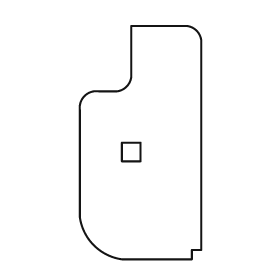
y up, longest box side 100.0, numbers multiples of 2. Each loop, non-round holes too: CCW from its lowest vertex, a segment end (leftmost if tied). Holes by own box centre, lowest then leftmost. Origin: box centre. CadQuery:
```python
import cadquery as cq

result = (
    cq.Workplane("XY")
    .moveTo(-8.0, -50.0)
    .lineTo(22.0, -50.0)
    .lineTo(22.0, -46.0)
    .lineTo(26.0, -46.0)
    .lineTo(26.0, 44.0)
    .threePointArc((24.0, 48.0), (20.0, 50.0))
    .lineTo(-4.0, 50.0)
    .lineTo(-4.0, 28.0)
    .threePointArc((-6.0, 24.0), (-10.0, 22.0))
    .lineTo(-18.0, 22.0)
    .threePointArc((-24.0, 20.0), (-26.0, 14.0))
    .lineTo(-26.0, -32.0)
    .threePointArc((-20.0, -44.0), (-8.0, -50.0))
    .close()
    .moveTo(-8.0, -8.0)
    .lineTo(0.0, -8.0)
    .lineTo(0.0, 0.0)
    .lineTo(-8.0, 0.0)
    .close()
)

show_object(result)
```